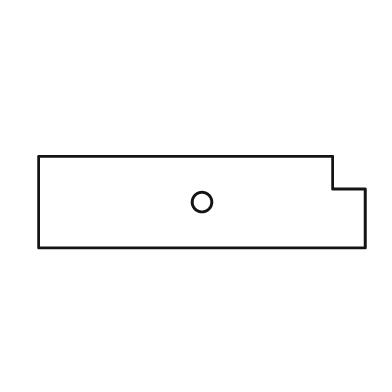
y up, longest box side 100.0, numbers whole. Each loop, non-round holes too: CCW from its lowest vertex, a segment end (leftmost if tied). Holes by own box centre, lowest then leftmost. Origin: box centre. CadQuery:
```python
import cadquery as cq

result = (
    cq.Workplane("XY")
    .moveTo(-50.0, -14.0)
    .lineTo(50.0, -14.0)
    .lineTo(50.0, 4.0)
    .lineTo(40.0, 4.0)
    .lineTo(40.0, 14.0)
    .lineTo(-50.0, 14.0)
    .close()
    .moveTo(0.0, 0.0)
    .circle(3.0)
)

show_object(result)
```